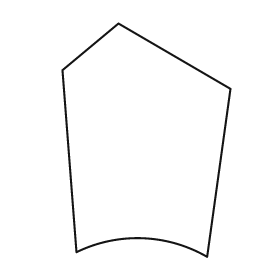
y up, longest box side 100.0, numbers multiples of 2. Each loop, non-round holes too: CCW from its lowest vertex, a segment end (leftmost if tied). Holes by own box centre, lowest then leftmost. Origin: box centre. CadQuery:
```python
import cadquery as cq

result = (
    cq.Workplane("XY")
    .moveTo(26.0, -50.0)
    .lineTo(36.0, 22.0)
    .lineTo(-12.0, 50.0)
    .lineTo(-36.0, 30.0)
    .lineTo(-30.0, -48.0)
    .threePointArc((-2.0, -42.0), (26.0, -50.0))
    .close()
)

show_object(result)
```